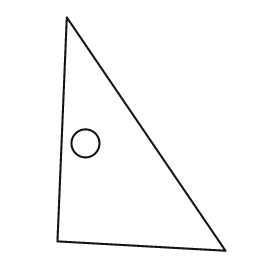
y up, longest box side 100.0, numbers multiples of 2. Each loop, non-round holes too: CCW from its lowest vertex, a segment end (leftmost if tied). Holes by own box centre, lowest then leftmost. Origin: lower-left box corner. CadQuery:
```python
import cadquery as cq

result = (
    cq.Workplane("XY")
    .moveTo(72.0, 0.0)
    .lineTo(4.0, 100.0)
    .lineTo(0.0, 4.0)
    .close()
    .moveTo(12.0, 46.0)
    .circle(6.0)
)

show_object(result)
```